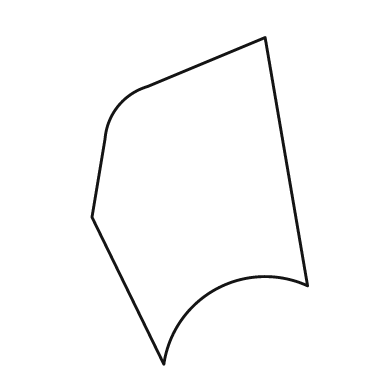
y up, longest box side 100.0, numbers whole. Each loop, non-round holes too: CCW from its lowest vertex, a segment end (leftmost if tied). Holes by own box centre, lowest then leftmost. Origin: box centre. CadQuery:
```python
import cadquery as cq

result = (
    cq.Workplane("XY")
    .moveTo(-11.0, -50.0)
    .threePointArc((5.0, -27.0), (33.0, -26.0))
    .lineTo(20.0, 50.0)
    .lineTo(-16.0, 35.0)
    .threePointArc((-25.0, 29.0), (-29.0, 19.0))
    .lineTo(-33.0, -5.0)
    .close()
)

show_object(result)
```